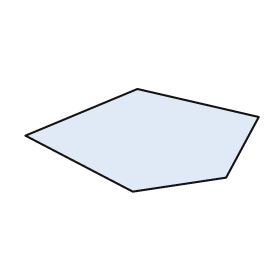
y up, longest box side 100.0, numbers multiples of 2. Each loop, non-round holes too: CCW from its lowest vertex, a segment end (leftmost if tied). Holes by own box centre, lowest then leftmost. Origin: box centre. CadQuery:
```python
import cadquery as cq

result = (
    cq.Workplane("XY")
    .moveTo(-4.0, -22.0)
    .lineTo(36.0, -16.0)
    .lineTo(50.0, 10.0)
    .lineTo(-2.0, 22.0)
    .lineTo(-50.0, 2.0)
    .close()
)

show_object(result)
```